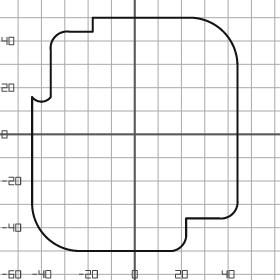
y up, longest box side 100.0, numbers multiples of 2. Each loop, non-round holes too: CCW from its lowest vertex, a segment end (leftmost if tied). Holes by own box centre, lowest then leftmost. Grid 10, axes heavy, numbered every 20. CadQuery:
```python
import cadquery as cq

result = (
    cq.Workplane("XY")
    .moveTo(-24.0, -50.0)
    .lineTo(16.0, -50.0)
    .threePointArc((20.0, -48.0), (22.0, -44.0))
    .lineTo(22.0, -36.0)
    .lineTo(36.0, -36.0)
    .threePointArc((42.0, -34.0), (44.0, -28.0))
    .lineTo(44.0, 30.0)
    .threePointArc((38.0, 44.0), (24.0, 50.0))
    .lineTo(-18.0, 50.0)
    .lineTo(-18.0, 44.0)
    .lineTo(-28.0, 44.0)
    .threePointArc((-34.0, 42.0), (-36.0, 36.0))
    .lineTo(-36.0, 16.0)
    .threePointArc((-40.0, 14.0), (-44.0, 16.0))
    .lineTo(-44.0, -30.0)
    .threePointArc((-38.0, -44.0), (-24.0, -50.0))
    .close()
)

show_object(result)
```